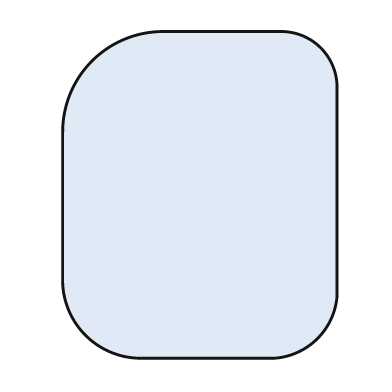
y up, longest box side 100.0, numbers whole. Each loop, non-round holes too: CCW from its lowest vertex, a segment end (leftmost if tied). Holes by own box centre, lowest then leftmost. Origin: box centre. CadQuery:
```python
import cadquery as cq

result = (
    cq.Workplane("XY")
    .moveTo(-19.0, -50.0)
    .lineTo(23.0, -50.0)
    .threePointArc((36.0, -44.0), (42.0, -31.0))
    .lineTo(42.0, 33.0)
    .threePointArc((37.0, 45.0), (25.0, 50.0))
    .lineTo(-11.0, 50.0)
    .threePointArc((-33.0, 41.0), (-42.0, 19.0))
    .lineTo(-42.0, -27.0)
    .threePointArc((-35.0, -43.0), (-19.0, -50.0))
    .close()
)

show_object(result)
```